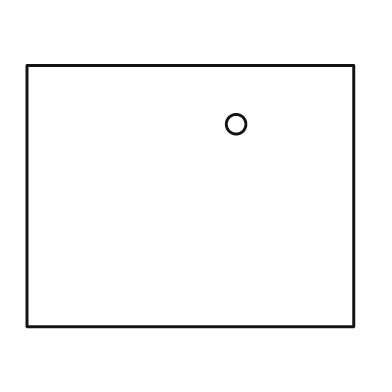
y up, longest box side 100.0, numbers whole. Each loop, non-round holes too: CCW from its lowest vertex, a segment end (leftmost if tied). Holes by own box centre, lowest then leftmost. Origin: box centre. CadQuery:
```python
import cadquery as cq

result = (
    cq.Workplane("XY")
    .moveTo(-50.0, -40.0)
    .lineTo(50.0, -40.0)
    .lineTo(50.0, 40.0)
    .lineTo(-50.0, 40.0)
    .close()
    .moveTo(14.0, 22.0)
    .circle(3.0)
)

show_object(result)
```